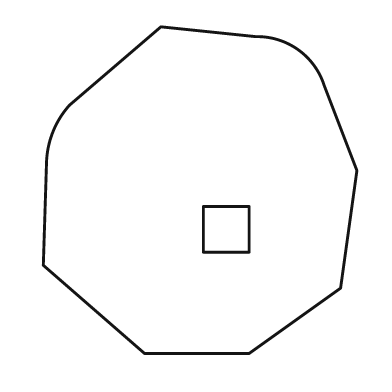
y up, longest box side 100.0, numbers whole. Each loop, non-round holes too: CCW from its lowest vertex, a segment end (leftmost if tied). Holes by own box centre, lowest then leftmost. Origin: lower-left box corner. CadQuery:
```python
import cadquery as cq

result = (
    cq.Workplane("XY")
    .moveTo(31.0, 0.0)
    .lineTo(63.0, 0.0)
    .lineTo(91.0, 20.0)
    .lineTo(96.0, 56.0)
    .lineTo(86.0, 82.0)
    .threePointArc((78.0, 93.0), (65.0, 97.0))
    .lineTo(36.0, 100.0)
    .lineTo(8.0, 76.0)
    .threePointArc((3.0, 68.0), (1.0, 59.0))
    .lineTo(0.0, 27.0)
    .close()
    .moveTo(49.0, 31.0)
    .lineTo(63.0, 31.0)
    .lineTo(63.0, 45.0)
    .lineTo(49.0, 45.0)
    .close()
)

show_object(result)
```